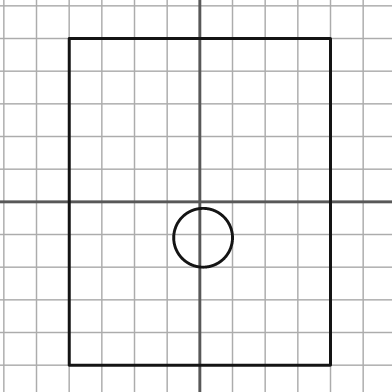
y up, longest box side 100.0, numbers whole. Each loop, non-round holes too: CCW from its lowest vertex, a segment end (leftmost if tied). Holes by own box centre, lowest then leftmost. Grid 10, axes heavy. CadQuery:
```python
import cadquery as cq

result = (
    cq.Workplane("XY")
    .moveTo(-40.0, -50.0)
    .lineTo(40.0, -50.0)
    .lineTo(40.0, 50.0)
    .lineTo(-40.0, 50.0)
    .close()
    .moveTo(1.0, -11.0)
    .circle(9.0)
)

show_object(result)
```